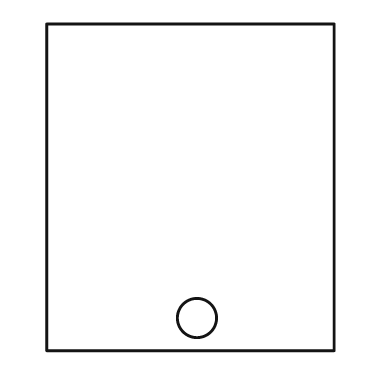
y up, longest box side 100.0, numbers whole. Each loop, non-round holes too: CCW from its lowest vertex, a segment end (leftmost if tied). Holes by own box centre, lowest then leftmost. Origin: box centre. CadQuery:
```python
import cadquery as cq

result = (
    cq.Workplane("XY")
    .moveTo(-44.0, -50.0)
    .lineTo(44.0, -50.0)
    .lineTo(44.0, 50.0)
    .lineTo(-44.0, 50.0)
    .close()
    .moveTo(2.0, -40.0)
    .circle(6.0)
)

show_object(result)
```